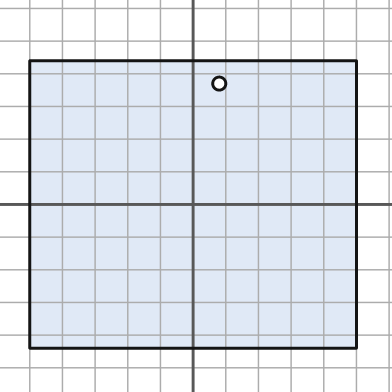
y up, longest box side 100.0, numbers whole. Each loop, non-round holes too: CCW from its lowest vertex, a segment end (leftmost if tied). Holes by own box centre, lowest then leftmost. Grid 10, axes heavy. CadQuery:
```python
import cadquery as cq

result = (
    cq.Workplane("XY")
    .moveTo(-50.0, -44.0)
    .lineTo(50.0, -44.0)
    .lineTo(50.0, 44.0)
    .lineTo(-50.0, 44.0)
    .close()
    .moveTo(8.0, 37.0)
    .circle(2.0)
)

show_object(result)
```